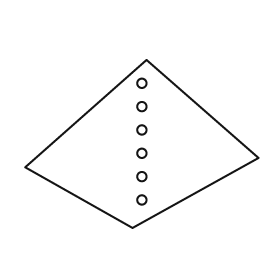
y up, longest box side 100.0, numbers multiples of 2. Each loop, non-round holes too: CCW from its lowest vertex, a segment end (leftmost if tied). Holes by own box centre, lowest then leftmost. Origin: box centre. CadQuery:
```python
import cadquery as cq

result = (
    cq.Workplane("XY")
    .moveTo(-4.0, -36.0)
    .lineTo(50.0, -6.0)
    .lineTo(2.0, 36.0)
    .lineTo(-50.0, -10.0)
    .close()
    .moveTo(0.0, -24.0)
    .circle(2.0)
    .moveTo(0.0, -14.0)
    .circle(2.0)
    .moveTo(0.0, -4.0)
    .circle(2.0)
    .moveTo(0.0, 6.0)
    .circle(2.0)
    .moveTo(0.0, 16.0)
    .circle(2.0)
    .moveTo(0.0, 26.0)
    .circle(2.0)
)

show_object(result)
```